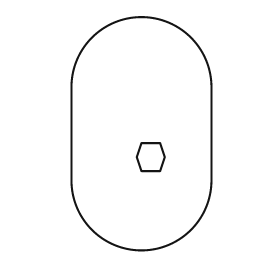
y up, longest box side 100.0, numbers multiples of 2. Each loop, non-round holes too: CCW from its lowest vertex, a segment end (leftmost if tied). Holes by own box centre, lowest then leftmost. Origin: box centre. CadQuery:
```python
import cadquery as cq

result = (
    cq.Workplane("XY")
    .moveTo(-30.0, -20.0)
    .threePointArc((0.0, -50.0), (30.0, -20.0))
    .lineTo(30.0, 20.0)
    .threePointArc((0.0, 50.0), (-30.0, 20.0))
    .close()
    .moveTo(0.0, -16.0)
    .lineTo(8.0, -16.0)
    .lineTo(10.0, -10.0)
    .lineTo(8.0, -4.0)
    .lineTo(0.0, -4.0)
    .lineTo(-2.0, -10.0)
    .close()
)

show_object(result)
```